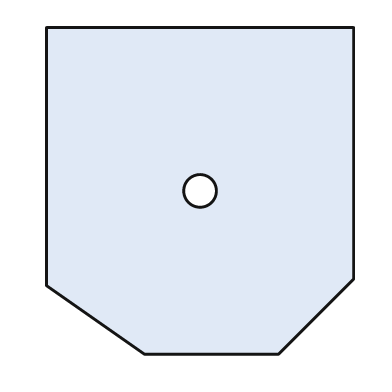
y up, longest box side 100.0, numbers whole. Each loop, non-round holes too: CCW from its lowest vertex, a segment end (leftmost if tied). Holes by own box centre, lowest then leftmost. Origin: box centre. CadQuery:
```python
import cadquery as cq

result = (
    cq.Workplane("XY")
    .moveTo(-17.0, -50.0)
    .lineTo(24.0, -50.0)
    .lineTo(47.0, -27.0)
    .lineTo(47.0, 50.0)
    .lineTo(-47.0, 50.0)
    .lineTo(-47.0, -29.0)
    .close()
    .moveTo(0.0, 0.0)
    .circle(5.0)
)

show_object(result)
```